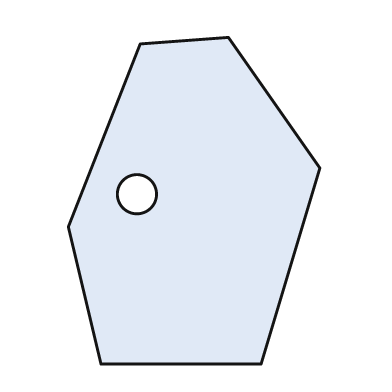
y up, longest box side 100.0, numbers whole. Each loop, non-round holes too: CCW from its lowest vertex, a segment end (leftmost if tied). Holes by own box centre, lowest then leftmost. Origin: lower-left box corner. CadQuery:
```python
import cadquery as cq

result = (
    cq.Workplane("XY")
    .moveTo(10.0, 0.0)
    .lineTo(59.0, 0.0)
    .lineTo(77.0, 60.0)
    .lineTo(49.0, 100.0)
    .lineTo(22.0, 98.0)
    .lineTo(0.0, 42.0)
    .close()
    .moveTo(21.0, 52.0)
    .circle(6.0)
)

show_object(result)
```